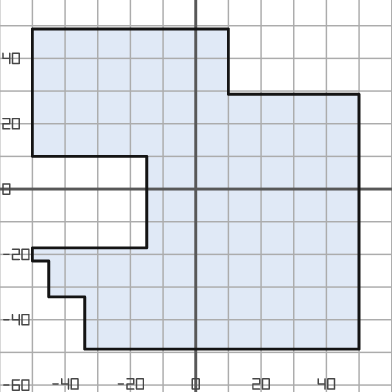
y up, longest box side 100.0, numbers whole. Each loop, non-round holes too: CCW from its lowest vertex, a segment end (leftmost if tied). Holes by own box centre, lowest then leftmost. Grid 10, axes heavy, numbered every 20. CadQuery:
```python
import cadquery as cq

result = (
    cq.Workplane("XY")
    .moveTo(-34.0, -49.0)
    .lineTo(50.0, -49.0)
    .lineTo(50.0, 29.0)
    .lineTo(10.0, 29.0)
    .lineTo(10.0, 49.0)
    .lineTo(-50.0, 49.0)
    .lineTo(-50.0, 10.0)
    .lineTo(-15.0, 10.0)
    .lineTo(-15.0, -18.0)
    .lineTo(-50.0, -18.0)
    .lineTo(-50.0, -22.0)
    .lineTo(-45.0, -22.0)
    .lineTo(-45.0, -33.0)
    .lineTo(-34.0, -33.0)
    .close()
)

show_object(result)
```